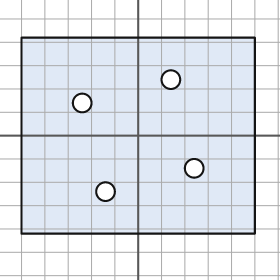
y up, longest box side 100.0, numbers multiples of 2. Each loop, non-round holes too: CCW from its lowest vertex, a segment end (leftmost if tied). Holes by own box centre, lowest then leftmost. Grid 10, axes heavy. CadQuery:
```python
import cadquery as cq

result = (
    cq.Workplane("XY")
    .moveTo(-50.0, -42.0)
    .lineTo(50.0, -42.0)
    .lineTo(50.0, 42.0)
    .lineTo(-50.0, 42.0)
    .close()
    .moveTo(-14.0, -24.0)
    .circle(4.0)
    .moveTo(24.0, -14.0)
    .circle(4.0)
    .moveTo(-24.0, 14.0)
    .circle(4.0)
    .moveTo(14.0, 24.0)
    .circle(4.0)
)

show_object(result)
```